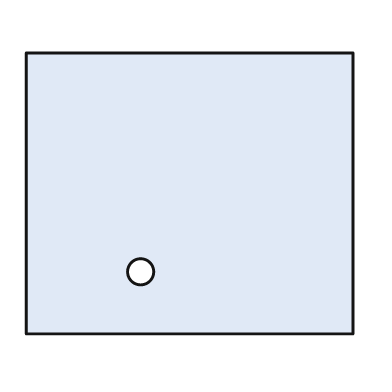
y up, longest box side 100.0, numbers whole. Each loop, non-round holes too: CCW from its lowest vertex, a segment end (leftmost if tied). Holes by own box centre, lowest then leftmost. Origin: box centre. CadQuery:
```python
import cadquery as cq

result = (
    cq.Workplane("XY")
    .moveTo(-50.0, -43.0)
    .lineTo(50.0, -43.0)
    .lineTo(50.0, 43.0)
    .lineTo(-50.0, 43.0)
    .close()
    .moveTo(-15.0, -24.0)
    .circle(4.0)
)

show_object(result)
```